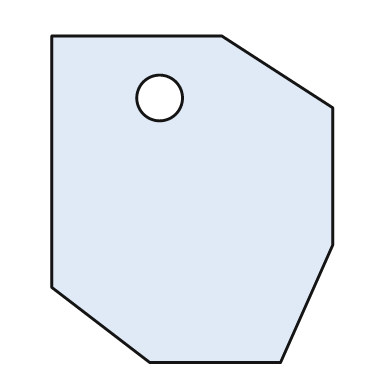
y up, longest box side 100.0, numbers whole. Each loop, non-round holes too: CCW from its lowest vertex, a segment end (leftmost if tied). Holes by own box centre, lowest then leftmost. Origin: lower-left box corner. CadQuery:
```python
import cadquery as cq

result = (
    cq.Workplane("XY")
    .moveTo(30.0, 0.0)
    .lineTo(70.0, 0.0)
    .lineTo(86.0, 36.0)
    .lineTo(86.0, 78.0)
    .lineTo(52.0, 100.0)
    .lineTo(0.0, 100.0)
    .lineTo(0.0, 23.0)
    .close()
    .moveTo(33.0, 81.0)
    .circle(7.0)
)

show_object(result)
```